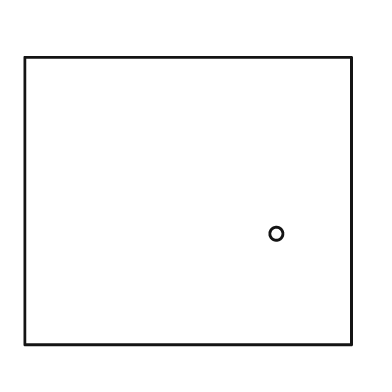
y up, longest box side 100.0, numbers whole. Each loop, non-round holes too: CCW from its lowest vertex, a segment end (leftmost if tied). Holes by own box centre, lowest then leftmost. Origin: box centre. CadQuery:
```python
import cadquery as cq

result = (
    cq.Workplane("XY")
    .moveTo(-50.0, -44.0)
    .lineTo(50.0, -44.0)
    .lineTo(50.0, 44.0)
    .lineTo(-50.0, 44.0)
    .close()
    .moveTo(27.0, -10.0)
    .circle(2.0)
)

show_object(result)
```